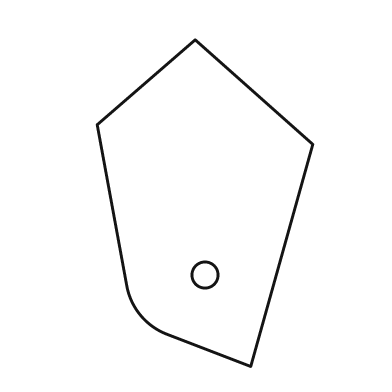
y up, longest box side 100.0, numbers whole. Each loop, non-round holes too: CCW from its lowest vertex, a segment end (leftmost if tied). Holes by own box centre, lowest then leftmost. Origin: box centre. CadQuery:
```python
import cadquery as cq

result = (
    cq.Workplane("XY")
    .moveTo(14.0, -50.0)
    .lineTo(33.0, 18.0)
    .lineTo(-3.0, 50.0)
    .lineTo(-33.0, 24.0)
    .lineTo(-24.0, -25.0)
    .threePointArc((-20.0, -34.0), (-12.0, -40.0))
    .close()
    .moveTo(0.0, -22.0)
    .circle(4.0)
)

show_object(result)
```